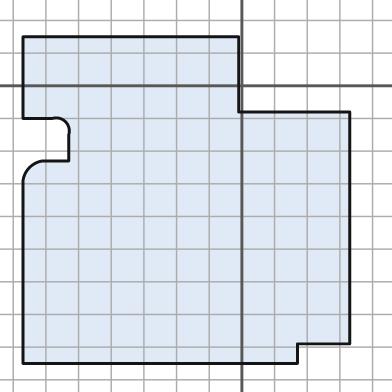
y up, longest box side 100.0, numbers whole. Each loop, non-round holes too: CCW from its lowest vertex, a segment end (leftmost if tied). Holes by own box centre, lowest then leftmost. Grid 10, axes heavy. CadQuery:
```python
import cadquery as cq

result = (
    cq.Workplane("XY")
    .moveTo(-67.0, -85.0)
    .lineTo(17.0, -85.0)
    .lineTo(17.0, -79.0)
    .lineTo(33.0, -79.0)
    .lineTo(33.0, -8.0)
    .lineTo(-1.0, -8.0)
    .lineTo(-1.0, 15.0)
    .lineTo(-67.0, 15.0)
    .lineTo(-67.0, -10.0)
    .lineTo(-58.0, -10.0)
    .threePointArc((-54.0, -11.0), (-53.0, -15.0))
    .lineTo(-53.0, -23.0)
    .lineTo(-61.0, -23.0)
    .threePointArc((-65.0, -25.0), (-67.0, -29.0))
    .close()
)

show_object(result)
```